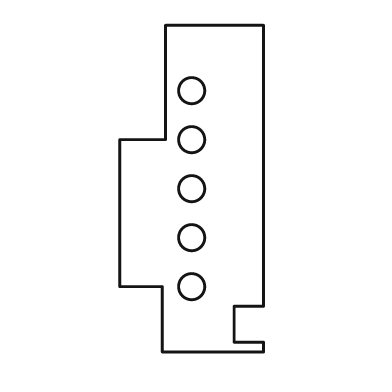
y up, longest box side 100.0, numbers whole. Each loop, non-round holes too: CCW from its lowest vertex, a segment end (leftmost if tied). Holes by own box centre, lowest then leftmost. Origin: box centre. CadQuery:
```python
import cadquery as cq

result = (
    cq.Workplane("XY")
    .moveTo(-9.0, -50.0)
    .lineTo(22.0, -50.0)
    .lineTo(22.0, -47.0)
    .lineTo(13.0, -47.0)
    .lineTo(13.0, -36.0)
    .lineTo(22.0, -36.0)
    .lineTo(22.0, 50.0)
    .lineTo(-8.0, 50.0)
    .lineTo(-8.0, 15.0)
    .lineTo(-22.0, 15.0)
    .lineTo(-22.0, -30.0)
    .lineTo(-9.0, -30.0)
    .close()
    .moveTo(0.0, -30.0)
    .circle(4.0)
    .moveTo(0.0, -15.0)
    .circle(4.0)
    .moveTo(0.0, 0.0)
    .circle(4.0)
    .moveTo(0.0, 15.0)
    .circle(4.0)
    .moveTo(0.0, 30.0)
    .circle(4.0)
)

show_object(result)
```